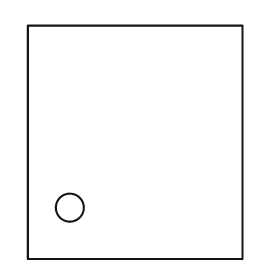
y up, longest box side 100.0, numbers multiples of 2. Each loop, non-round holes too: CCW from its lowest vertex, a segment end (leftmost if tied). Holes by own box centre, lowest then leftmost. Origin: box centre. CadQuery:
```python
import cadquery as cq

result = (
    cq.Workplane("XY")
    .moveTo(-46.0, -50.0)
    .lineTo(46.0, -50.0)
    .lineTo(46.0, 50.0)
    .lineTo(-46.0, 50.0)
    .close()
    .moveTo(-28.0, -28.0)
    .circle(6.0)
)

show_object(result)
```